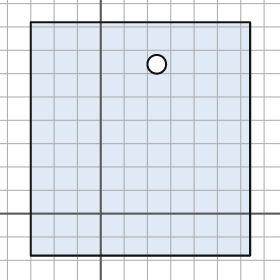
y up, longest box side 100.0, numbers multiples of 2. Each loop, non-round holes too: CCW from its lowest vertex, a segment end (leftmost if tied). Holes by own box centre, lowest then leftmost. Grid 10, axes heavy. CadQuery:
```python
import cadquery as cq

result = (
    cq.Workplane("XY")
    .moveTo(-30.0, -18.0)
    .lineTo(64.0, -18.0)
    .lineTo(64.0, 82.0)
    .lineTo(-30.0, 82.0)
    .close()
    .moveTo(24.0, 64.0)
    .circle(4.0)
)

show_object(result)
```